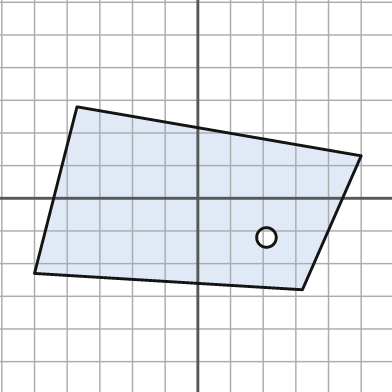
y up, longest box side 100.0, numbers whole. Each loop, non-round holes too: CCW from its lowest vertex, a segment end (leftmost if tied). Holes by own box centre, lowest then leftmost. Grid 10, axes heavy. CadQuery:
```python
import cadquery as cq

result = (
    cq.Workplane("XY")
    .moveTo(32.0, -28.0)
    .lineTo(50.0, 13.0)
    .lineTo(-37.0, 28.0)
    .lineTo(-50.0, -23.0)
    .close()
    .moveTo(21.0, -12.0)
    .circle(3.0)
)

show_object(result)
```